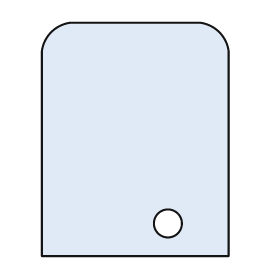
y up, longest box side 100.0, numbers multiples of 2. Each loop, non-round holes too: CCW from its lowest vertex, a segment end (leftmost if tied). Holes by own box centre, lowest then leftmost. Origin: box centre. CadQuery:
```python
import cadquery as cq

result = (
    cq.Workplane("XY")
    .moveTo(-40.0, -50.0)
    .lineTo(40.0, -50.0)
    .lineTo(40.0, 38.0)
    .threePointArc((36.0, 46.0), (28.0, 50.0))
    .lineTo(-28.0, 50.0)
    .threePointArc((-36.0, 46.0), (-40.0, 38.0))
    .close()
    .moveTo(14.0, -36.0)
    .circle(6.0)
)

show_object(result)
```